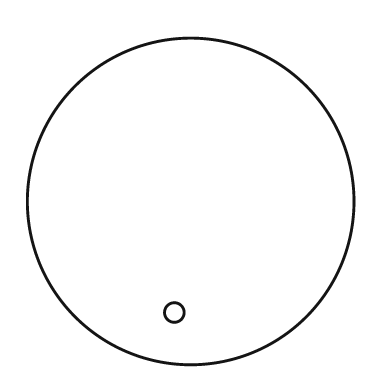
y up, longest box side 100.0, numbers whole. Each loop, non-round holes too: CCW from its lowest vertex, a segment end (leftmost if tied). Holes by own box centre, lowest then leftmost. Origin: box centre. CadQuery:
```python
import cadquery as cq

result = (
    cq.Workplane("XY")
    .moveTo(0.0, 0.0)
    .circle(50.0)
    .moveTo(-5.0, -34.0)
    .circle(3.0)
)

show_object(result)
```